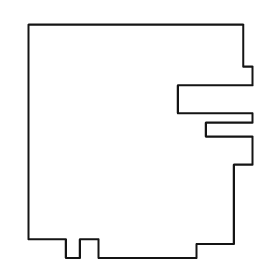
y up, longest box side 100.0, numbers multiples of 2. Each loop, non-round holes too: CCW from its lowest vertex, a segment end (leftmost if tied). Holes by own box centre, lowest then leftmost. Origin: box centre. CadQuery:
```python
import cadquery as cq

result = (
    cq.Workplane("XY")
    .moveTo(-32.0, -50.0)
    .lineTo(-26.0, -50.0)
    .lineTo(-26.0, -42.0)
    .lineTo(-18.0, -42.0)
    .lineTo(-18.0, -50.0)
    .lineTo(24.0, -50.0)
    .lineTo(24.0, -44.0)
    .lineTo(40.0, -44.0)
    .lineTo(40.0, -10.0)
    .lineTo(48.0, -10.0)
    .lineTo(48.0, 2.0)
    .lineTo(28.0, 2.0)
    .lineTo(28.0, 8.0)
    .lineTo(48.0, 8.0)
    .lineTo(48.0, 12.0)
    .lineTo(16.0, 12.0)
    .lineTo(16.0, 24.0)
    .lineTo(48.0, 24.0)
    .lineTo(48.0, 32.0)
    .lineTo(44.0, 32.0)
    .lineTo(44.0, 50.0)
    .lineTo(-48.0, 50.0)
    .lineTo(-48.0, -42.0)
    .lineTo(-32.0, -42.0)
    .close()
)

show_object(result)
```